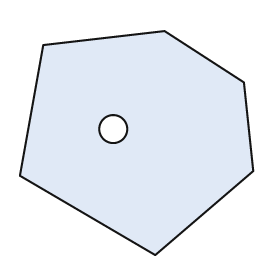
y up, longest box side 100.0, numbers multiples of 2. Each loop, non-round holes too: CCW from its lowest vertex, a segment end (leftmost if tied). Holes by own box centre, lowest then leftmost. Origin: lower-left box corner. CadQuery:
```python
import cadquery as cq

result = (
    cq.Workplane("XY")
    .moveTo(58.0, 0.0)
    .lineTo(100.0, 36.0)
    .lineTo(96.0, 74.0)
    .lineTo(62.0, 96.0)
    .lineTo(10.0, 90.0)
    .lineTo(0.0, 34.0)
    .close()
    .moveTo(40.0, 54.0)
    .circle(6.0)
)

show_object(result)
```